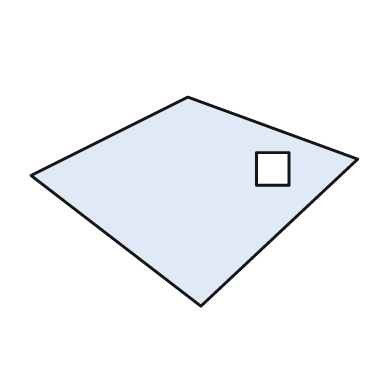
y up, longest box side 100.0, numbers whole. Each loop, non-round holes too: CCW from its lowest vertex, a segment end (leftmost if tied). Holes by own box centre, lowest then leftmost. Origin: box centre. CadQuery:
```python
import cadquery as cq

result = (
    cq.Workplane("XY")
    .moveTo(2.0, -32.0)
    .lineTo(50.0, 13.0)
    .lineTo(-2.0, 32.0)
    .lineTo(-50.0, 8.0)
    .close()
    .moveTo(19.0, 5.0)
    .lineTo(29.0, 5.0)
    .lineTo(29.0, 15.0)
    .lineTo(19.0, 15.0)
    .close()
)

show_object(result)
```